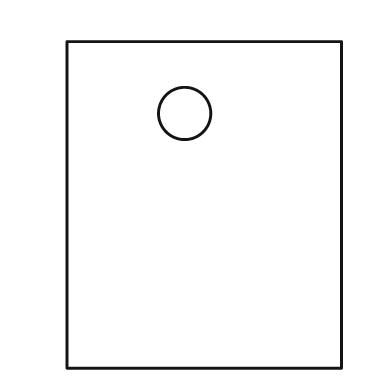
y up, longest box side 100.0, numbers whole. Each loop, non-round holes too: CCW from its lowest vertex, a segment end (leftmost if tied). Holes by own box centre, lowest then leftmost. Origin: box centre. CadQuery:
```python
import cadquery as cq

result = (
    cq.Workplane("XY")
    .moveTo(-42.0, -50.0)
    .lineTo(42.0, -50.0)
    .lineTo(42.0, 50.0)
    .lineTo(-42.0, 50.0)
    .close()
    .moveTo(-6.0, 28.0)
    .circle(8.0)
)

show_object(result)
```